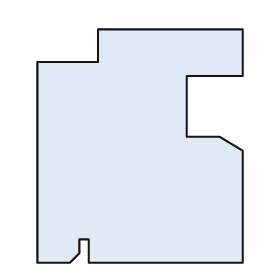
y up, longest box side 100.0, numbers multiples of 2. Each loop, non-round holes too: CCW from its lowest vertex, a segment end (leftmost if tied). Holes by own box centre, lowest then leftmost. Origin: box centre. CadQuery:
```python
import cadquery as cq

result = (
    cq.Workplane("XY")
    .moveTo(-44.0, -50.0)
    .lineTo(-30.0, -50.0)
    .lineTo(-26.0, -46.0)
    .lineTo(-26.0, -40.0)
    .lineTo(-22.0, -40.0)
    .lineTo(-22.0, -50.0)
    .lineTo(44.0, -50.0)
    .lineTo(44.0, -2.0)
    .lineTo(34.0, 4.0)
    .lineTo(20.0, 4.0)
    .lineTo(20.0, 30.0)
    .lineTo(44.0, 30.0)
    .lineTo(44.0, 50.0)
    .lineTo(-18.0, 50.0)
    .lineTo(-18.0, 36.0)
    .lineTo(-44.0, 36.0)
    .close()
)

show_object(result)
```